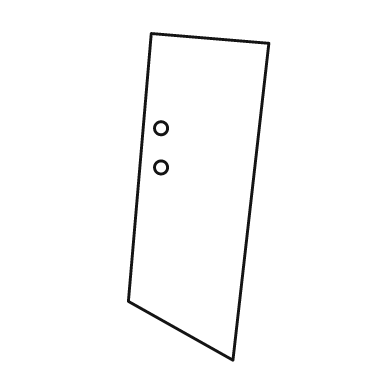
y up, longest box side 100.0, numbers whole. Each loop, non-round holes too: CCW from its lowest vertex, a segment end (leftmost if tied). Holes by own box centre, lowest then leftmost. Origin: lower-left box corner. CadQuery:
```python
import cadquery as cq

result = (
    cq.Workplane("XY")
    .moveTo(32.0, 0.0)
    .lineTo(43.0, 97.0)
    .lineTo(7.0, 100.0)
    .lineTo(0.0, 18.0)
    .close()
    .moveTo(10.0, 59.0)
    .circle(2.0)
    .moveTo(10.0, 71.0)
    .circle(2.0)
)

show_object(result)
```